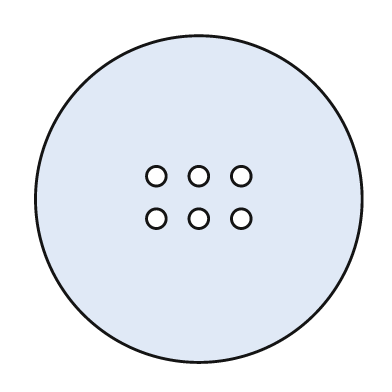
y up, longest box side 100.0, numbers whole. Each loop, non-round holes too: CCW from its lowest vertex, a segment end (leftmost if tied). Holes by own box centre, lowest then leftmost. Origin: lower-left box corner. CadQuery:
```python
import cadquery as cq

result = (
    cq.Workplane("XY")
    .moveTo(50.0, 50.0)
    .circle(50.0)
    .moveTo(37.0, 44.0)
    .circle(3.0)
    .moveTo(50.0, 44.0)
    .circle(3.0)
    .moveTo(63.0, 44.0)
    .circle(3.0)
    .moveTo(37.0, 57.0)
    .circle(3.0)
    .moveTo(50.0, 57.0)
    .circle(3.0)
    .moveTo(63.0, 57.0)
    .circle(3.0)
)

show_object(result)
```